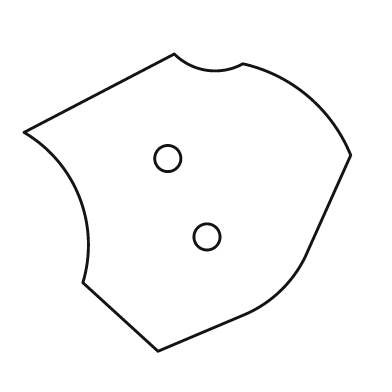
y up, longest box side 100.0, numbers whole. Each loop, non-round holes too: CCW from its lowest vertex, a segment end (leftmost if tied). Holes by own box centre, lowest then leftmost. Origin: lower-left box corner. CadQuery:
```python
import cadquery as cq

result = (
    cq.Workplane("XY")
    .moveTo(41.0, 0.0)
    .lineTo(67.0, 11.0)
    .threePointArc((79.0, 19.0), (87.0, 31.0))
    .lineTo(100.0, 60.0)
    .threePointArc((87.0, 78.0), (67.0, 88.0))
    .threePointArc((56.0, 86.0), (46.0, 91.0))
    .lineTo(0.0, 67.0)
    .threePointArc((17.0, 47.0), (18.0, 21.0))
    .close()
    .moveTo(56.0, 35.0)
    .circle(4.0)
    .moveTo(44.0, 59.0)
    .circle(4.0)
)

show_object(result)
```